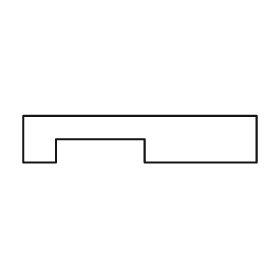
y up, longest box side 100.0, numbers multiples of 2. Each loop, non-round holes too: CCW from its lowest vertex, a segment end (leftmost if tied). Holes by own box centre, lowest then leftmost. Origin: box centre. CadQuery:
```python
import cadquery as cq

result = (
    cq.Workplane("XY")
    .moveTo(-50.0, -10.0)
    .lineTo(-36.0, -10.0)
    .lineTo(-36.0, 0.0)
    .lineTo(2.0, 0.0)
    .lineTo(2.0, -10.0)
    .lineTo(50.0, -10.0)
    .lineTo(50.0, 10.0)
    .lineTo(-50.0, 10.0)
    .close()
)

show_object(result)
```